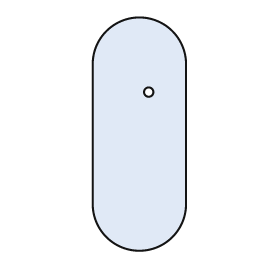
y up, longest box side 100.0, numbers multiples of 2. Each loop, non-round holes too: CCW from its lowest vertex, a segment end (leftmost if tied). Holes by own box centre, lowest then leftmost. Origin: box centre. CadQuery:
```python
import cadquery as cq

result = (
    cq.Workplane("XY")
    .moveTo(-20.0, -30.0)
    .threePointArc((0.0, -50.0), (20.0, -30.0))
    .lineTo(20.0, 30.0)
    .threePointArc((0.0, 50.0), (-20.0, 30.0))
    .close()
    .moveTo(4.0, 18.0)
    .circle(2.0)
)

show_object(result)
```